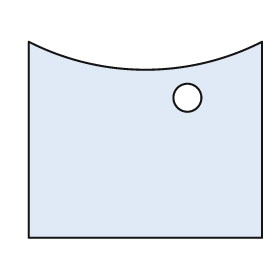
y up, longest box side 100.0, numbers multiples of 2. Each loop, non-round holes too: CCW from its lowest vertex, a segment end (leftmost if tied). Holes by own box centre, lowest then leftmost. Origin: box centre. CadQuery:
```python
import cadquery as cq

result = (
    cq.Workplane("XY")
    .moveTo(-50.0, -42.0)
    .lineTo(50.0, -42.0)
    .lineTo(50.0, 42.0)
    .threePointArc((0.0, 30.0), (-50.0, 42.0))
    .close()
    .moveTo(18.0, 18.0)
    .circle(6.0)
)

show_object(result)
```